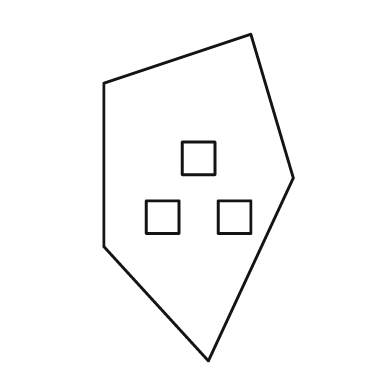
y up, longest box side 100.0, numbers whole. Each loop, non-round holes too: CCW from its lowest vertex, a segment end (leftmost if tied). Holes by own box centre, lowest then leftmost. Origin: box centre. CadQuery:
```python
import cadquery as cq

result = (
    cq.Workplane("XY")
    .moveTo(3.0, -50.0)
    .lineTo(29.0, 6.0)
    .lineTo(16.0, 50.0)
    .lineTo(-29.0, 35.0)
    .lineTo(-29.0, -15.0)
    .close()
    .moveTo(-16.0, -11.0)
    .lineTo(-6.0, -11.0)
    .lineTo(-6.0, -1.0)
    .lineTo(-16.0, -1.0)
    .close()
    .moveTo(6.0, -11.0)
    .lineTo(16.0, -11.0)
    .lineTo(16.0, -1.0)
    .lineTo(6.0, -1.0)
    .close()
    .moveTo(-5.0, 7.0)
    .lineTo(5.0, 7.0)
    .lineTo(5.0, 17.0)
    .lineTo(-5.0, 17.0)
    .close()
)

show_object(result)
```